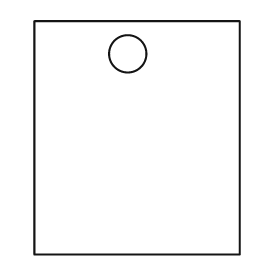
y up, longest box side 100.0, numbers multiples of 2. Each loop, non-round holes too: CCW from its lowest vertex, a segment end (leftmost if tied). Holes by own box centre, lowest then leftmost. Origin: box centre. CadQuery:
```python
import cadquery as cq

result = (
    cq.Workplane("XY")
    .moveTo(-44.0, -50.0)
    .lineTo(44.0, -50.0)
    .lineTo(44.0, 50.0)
    .lineTo(-44.0, 50.0)
    .close()
    .moveTo(-4.0, 36.0)
    .circle(8.0)
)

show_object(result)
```